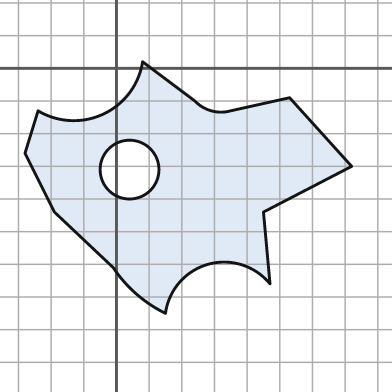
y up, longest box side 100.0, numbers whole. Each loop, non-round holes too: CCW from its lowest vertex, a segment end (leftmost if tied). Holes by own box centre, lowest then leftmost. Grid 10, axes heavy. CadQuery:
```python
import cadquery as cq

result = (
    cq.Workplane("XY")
    .moveTo(15.0, -75.0)
    .threePointArc((28.0, -60.0), (47.0, -66.0))
    .lineTo(45.0, -44.0)
    .lineTo(72.0, -30.0)
    .lineTo(53.0, -9.0)
    .lineTo(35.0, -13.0)
    .threePointArc((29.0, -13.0), (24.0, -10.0))
    .lineTo(8.0, 2.0)
    .threePointArc((-4.0, -14.0), (-24.0, -13.0))
    .lineTo(-28.0, -26.0)
    .lineTo(-19.0, -44.0)
    .lineTo(-1.0, -61.0)
    .threePointArc((6.0, -69.0), (15.0, -75.0))
    .close()
    .moveTo(4.0, -31.0)
    .circle(9.0)
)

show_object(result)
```